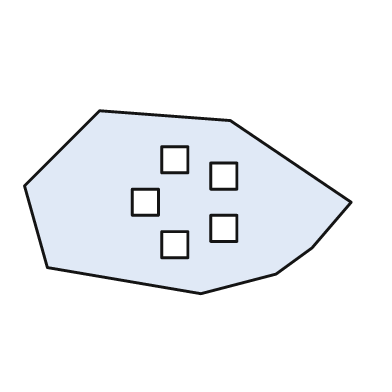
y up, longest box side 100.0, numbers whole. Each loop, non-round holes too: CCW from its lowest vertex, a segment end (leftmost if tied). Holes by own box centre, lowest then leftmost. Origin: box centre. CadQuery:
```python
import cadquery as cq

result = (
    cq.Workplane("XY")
    .moveTo(4.0, -28.0)
    .lineTo(27.0, -22.0)
    .lineTo(38.0, -14.0)
    .lineTo(50.0, 0.0)
    .lineTo(13.0, 25.0)
    .lineTo(-27.0, 28.0)
    .lineTo(-50.0, 5.0)
    .lineTo(-43.0, -20.0)
    .close()
    .moveTo(-8.0, -17.0)
    .lineTo(0.0, -17.0)
    .lineTo(0.0, -9.0)
    .lineTo(-8.0, -9.0)
    .close()
    .moveTo(7.0, -12.0)
    .lineTo(15.0, -12.0)
    .lineTo(15.0, -4.0)
    .lineTo(7.0, -4.0)
    .close()
    .moveTo(-17.0, -4.0)
    .lineTo(-9.0, -4.0)
    .lineTo(-9.0, 4.0)
    .lineTo(-17.0, 4.0)
    .close()
    .moveTo(7.0, 4.0)
    .lineTo(15.0, 4.0)
    .lineTo(15.0, 12.0)
    .lineTo(7.0, 12.0)
    .close()
    .moveTo(-8.0, 9.0)
    .lineTo(0.0, 9.0)
    .lineTo(0.0, 17.0)
    .lineTo(-8.0, 17.0)
    .close()
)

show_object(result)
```